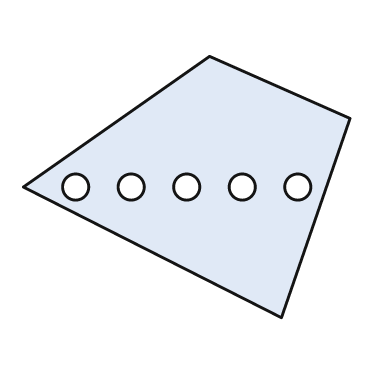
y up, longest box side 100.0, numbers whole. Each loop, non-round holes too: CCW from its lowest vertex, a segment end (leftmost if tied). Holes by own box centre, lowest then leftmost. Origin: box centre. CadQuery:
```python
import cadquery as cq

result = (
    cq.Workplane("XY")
    .moveTo(29.0, -40.0)
    .lineTo(50.0, 21.0)
    .lineTo(7.0, 40.0)
    .lineTo(-50.0, 0.0)
    .close()
    .moveTo(-34.0, 0.0)
    .circle(4.0)
    .moveTo(-17.0, 0.0)
    .circle(4.0)
    .moveTo(0.0, 0.0)
    .circle(4.0)
    .moveTo(17.0, 0.0)
    .circle(4.0)
    .moveTo(34.0, 0.0)
    .circle(4.0)
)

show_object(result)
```